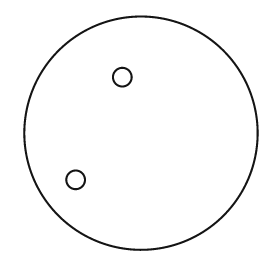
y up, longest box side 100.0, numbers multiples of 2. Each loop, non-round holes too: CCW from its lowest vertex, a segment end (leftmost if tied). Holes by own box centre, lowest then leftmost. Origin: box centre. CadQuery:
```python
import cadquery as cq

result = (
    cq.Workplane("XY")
    .moveTo(0.0, 0.0)
    .circle(50.0)
    .moveTo(-28.0, -20.0)
    .circle(4.0)
    .moveTo(-8.0, 24.0)
    .circle(4.0)
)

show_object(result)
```